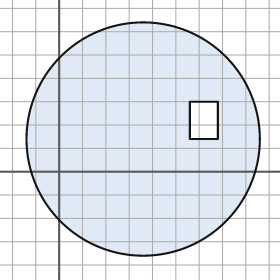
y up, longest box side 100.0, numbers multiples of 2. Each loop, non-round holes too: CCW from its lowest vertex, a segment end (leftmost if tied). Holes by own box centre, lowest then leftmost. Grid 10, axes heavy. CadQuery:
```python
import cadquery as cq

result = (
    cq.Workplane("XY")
    .moveTo(36.0, 14.0)
    .circle(50.0)
    .moveTo(56.0, 14.0)
    .lineTo(68.0, 14.0)
    .lineTo(68.0, 30.0)
    .lineTo(56.0, 30.0)
    .close()
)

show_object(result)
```